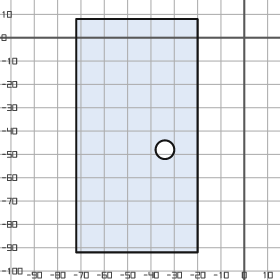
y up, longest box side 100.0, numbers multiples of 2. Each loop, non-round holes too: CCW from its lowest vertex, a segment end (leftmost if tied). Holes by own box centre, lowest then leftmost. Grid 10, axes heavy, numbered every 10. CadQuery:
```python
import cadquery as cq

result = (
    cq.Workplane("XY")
    .moveTo(-72.0, -92.0)
    .lineTo(-20.0, -92.0)
    .lineTo(-20.0, 8.0)
    .lineTo(-72.0, 8.0)
    .close()
    .moveTo(-34.0, -48.0)
    .circle(4.0)
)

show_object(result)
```